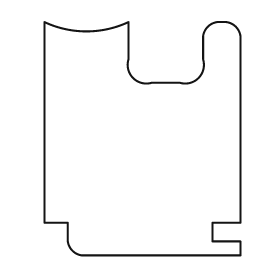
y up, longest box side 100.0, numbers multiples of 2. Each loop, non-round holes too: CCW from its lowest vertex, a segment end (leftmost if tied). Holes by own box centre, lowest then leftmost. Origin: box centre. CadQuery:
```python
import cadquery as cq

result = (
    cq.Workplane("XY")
    .moveTo(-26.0, -50.0)
    .lineTo(42.0, -50.0)
    .lineTo(42.0, -44.0)
    .lineTo(30.0, -44.0)
    .lineTo(30.0, -36.0)
    .lineTo(42.0, -36.0)
    .lineTo(42.0, 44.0)
    .threePointArc((40.0, 48.0), (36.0, 50.0))
    .lineTo(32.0, 50.0)
    .threePointArc((28.0, 48.0), (26.0, 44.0))
    .lineTo(26.0, 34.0)
    .threePointArc((24.0, 26.0), (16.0, 24.0))
    .lineTo(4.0, 24.0)
    .threePointArc((-4.0, 26.0), (-6.0, 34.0))
    .lineTo(-6.0, 50.0)
    .threePointArc((-24.0, 46.0), (-42.0, 50.0))
    .lineTo(-42.0, -36.0)
    .lineTo(-32.0, -36.0)
    .lineTo(-32.0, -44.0)
    .threePointArc((-30.0, -48.0), (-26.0, -50.0))
    .close()
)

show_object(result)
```